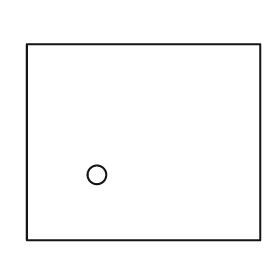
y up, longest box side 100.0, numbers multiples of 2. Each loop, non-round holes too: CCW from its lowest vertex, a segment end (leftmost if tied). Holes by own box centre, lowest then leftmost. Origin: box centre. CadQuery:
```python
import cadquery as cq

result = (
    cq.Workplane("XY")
    .moveTo(-50.0, -42.0)
    .lineTo(50.0, -42.0)
    .lineTo(50.0, 42.0)
    .lineTo(-50.0, 42.0)
    .close()
    .moveTo(-20.0, -14.0)
    .circle(4.0)
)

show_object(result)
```